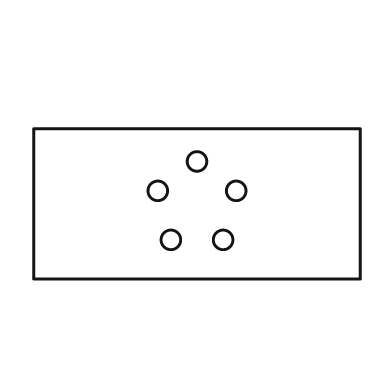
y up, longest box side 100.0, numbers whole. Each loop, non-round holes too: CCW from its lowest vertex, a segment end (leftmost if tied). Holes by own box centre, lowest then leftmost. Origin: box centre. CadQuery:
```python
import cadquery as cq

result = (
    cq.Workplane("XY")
    .moveTo(-50.0, -23.0)
    .lineTo(50.0, -23.0)
    .lineTo(50.0, 23.0)
    .lineTo(-50.0, 23.0)
    .close()
    .moveTo(-8.0, -11.0)
    .circle(3.0)
    .moveTo(8.0, -11.0)
    .circle(3.0)
    .moveTo(-12.0, 4.0)
    .circle(3.0)
    .moveTo(12.0, 4.0)
    .circle(3.0)
    .moveTo(0.0, 13.0)
    .circle(3.0)
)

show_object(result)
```